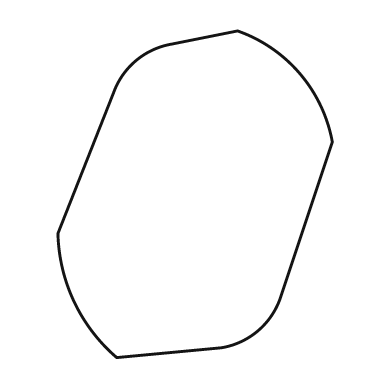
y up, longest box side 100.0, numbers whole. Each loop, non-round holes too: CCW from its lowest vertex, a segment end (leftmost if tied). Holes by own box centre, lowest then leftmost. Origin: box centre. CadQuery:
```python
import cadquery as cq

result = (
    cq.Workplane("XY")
    .moveTo(-24.0, -50.0)
    .lineTo(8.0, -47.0)
    .threePointArc((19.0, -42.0), (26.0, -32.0))
    .lineTo(42.0, 16.0)
    .threePointArc((32.0, 37.0), (13.0, 50.0))
    .lineTo(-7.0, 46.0)
    .threePointArc((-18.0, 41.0), (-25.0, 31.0))
    .lineTo(-42.0, -12.0)
    .threePointArc((-37.0, -33.0), (-24.0, -50.0))
    .close()
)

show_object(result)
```